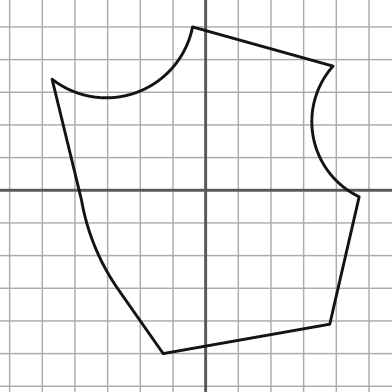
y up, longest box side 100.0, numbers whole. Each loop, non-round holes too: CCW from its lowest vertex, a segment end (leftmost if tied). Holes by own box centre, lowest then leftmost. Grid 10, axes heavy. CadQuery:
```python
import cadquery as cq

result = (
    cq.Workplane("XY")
    .moveTo(-13.0, -50.0)
    .lineTo(38.0, -41.0)
    .lineTo(47.0, -2.0)
    .threePointArc((33.0, 16.0), (39.0, 38.0))
    .lineTo(-4.0, 50.0)
    .threePointArc((-21.0, 30.0), (-47.0, 34.0))
    .lineTo(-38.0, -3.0)
    .threePointArc((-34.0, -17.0), (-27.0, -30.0))
    .close()
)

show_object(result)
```